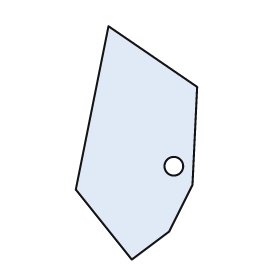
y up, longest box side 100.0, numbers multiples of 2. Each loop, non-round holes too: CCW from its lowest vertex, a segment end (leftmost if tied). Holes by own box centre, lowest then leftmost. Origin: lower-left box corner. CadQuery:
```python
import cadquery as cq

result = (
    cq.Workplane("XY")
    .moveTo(24.0, 0.0)
    .lineTo(40.0, 12.0)
    .lineTo(50.0, 32.0)
    .lineTo(52.0, 74.0)
    .lineTo(14.0, 100.0)
    .lineTo(0.0, 30.0)
    .close()
    .moveTo(42.0, 40.0)
    .circle(4.0)
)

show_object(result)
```